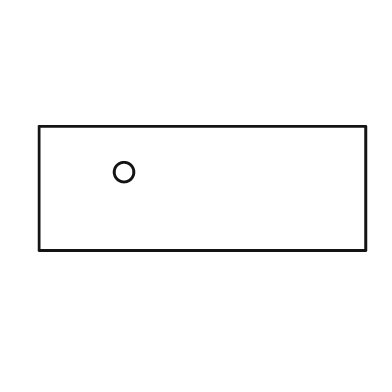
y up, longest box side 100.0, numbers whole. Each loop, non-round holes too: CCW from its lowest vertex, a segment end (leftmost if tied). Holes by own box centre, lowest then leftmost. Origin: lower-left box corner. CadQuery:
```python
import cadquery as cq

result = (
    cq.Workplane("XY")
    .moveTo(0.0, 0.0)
    .lineTo(100.0, 0.0)
    .lineTo(100.0, 38.0)
    .lineTo(0.0, 38.0)
    .close()
    .moveTo(26.0, 24.0)
    .circle(3.0)
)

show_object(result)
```